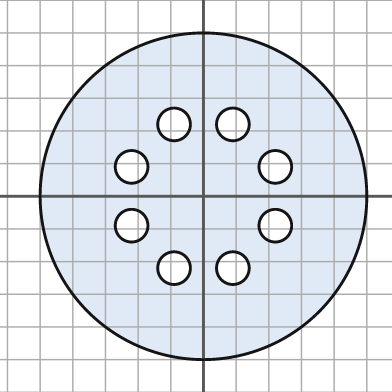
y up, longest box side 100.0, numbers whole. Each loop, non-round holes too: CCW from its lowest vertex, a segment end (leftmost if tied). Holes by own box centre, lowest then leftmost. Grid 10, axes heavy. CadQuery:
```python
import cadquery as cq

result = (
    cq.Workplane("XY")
    .moveTo(0.0, 0.0)
    .circle(50.0)
    .moveTo(-9.0, -22.0)
    .circle(5.0)
    .moveTo(9.0, -22.0)
    .circle(5.0)
    .moveTo(-22.0, -9.0)
    .circle(5.0)
    .moveTo(22.0, -9.0)
    .circle(5.0)
    .moveTo(-22.0, 9.0)
    .circle(5.0)
    .moveTo(22.0, 9.0)
    .circle(5.0)
    .moveTo(-9.0, 22.0)
    .circle(5.0)
    .moveTo(9.0, 22.0)
    .circle(5.0)
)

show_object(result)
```